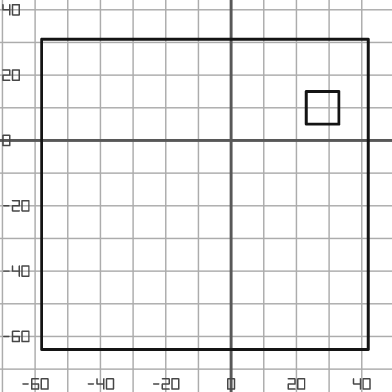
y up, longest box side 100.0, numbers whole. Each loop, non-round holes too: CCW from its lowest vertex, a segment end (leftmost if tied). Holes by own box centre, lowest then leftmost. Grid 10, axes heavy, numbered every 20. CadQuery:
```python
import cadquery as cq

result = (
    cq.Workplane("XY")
    .moveTo(-58.0, -64.0)
    .lineTo(42.0, -64.0)
    .lineTo(42.0, 31.0)
    .lineTo(-58.0, 31.0)
    .close()
    .moveTo(23.0, 5.0)
    .lineTo(33.0, 5.0)
    .lineTo(33.0, 15.0)
    .lineTo(23.0, 15.0)
    .close()
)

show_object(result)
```